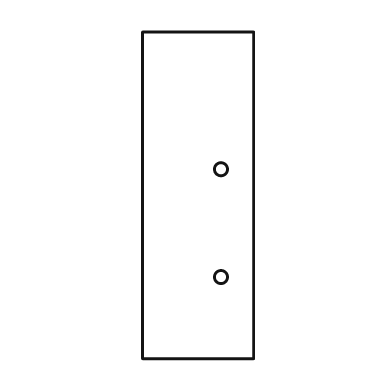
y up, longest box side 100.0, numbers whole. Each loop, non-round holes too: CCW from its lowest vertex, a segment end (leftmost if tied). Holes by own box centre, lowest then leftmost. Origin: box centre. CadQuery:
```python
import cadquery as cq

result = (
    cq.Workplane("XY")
    .moveTo(-17.0, -50.0)
    .lineTo(17.0, -50.0)
    .lineTo(17.0, 50.0)
    .lineTo(-17.0, 50.0)
    .close()
    .moveTo(7.0, -25.0)
    .circle(2.0)
    .moveTo(7.0, 8.0)
    .circle(2.0)
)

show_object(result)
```